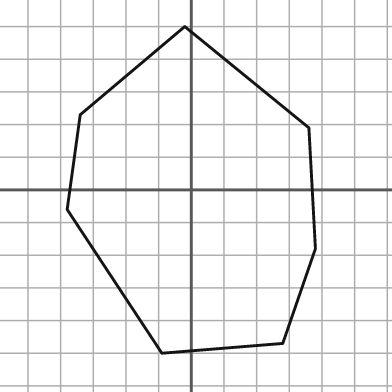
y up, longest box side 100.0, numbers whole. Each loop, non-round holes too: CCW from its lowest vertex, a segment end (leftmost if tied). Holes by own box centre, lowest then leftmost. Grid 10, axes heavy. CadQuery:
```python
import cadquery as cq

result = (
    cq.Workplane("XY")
    .moveTo(-9.0, -50.0)
    .lineTo(28.0, -47.0)
    .lineTo(38.0, -18.0)
    .lineTo(36.0, 19.0)
    .lineTo(-2.0, 50.0)
    .lineTo(-34.0, 23.0)
    .lineTo(-38.0, -6.0)
    .close()
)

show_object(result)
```